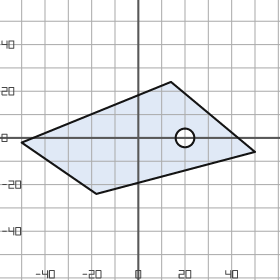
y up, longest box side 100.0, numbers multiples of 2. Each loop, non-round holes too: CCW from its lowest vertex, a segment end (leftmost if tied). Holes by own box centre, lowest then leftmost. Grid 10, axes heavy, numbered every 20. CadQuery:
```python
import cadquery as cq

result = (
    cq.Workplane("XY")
    .moveTo(-18.0, -24.0)
    .lineTo(50.0, -6.0)
    .lineTo(14.0, 24.0)
    .lineTo(-50.0, -2.0)
    .close()
    .moveTo(20.0, 0.0)
    .circle(4.0)
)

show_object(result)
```